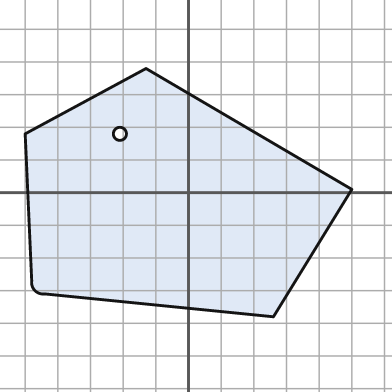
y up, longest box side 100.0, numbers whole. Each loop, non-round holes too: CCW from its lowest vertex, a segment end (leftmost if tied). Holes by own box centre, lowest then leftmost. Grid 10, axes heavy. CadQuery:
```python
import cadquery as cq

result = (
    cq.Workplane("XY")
    .moveTo(26.0, -38.0)
    .lineTo(50.0, 1.0)
    .lineTo(-13.0, 38.0)
    .lineTo(-50.0, 18.0)
    .lineTo(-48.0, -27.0)
    .threePointArc((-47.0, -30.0), (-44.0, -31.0))
    .close()
    .moveTo(-21.0, 18.0)
    .circle(2.0)
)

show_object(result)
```